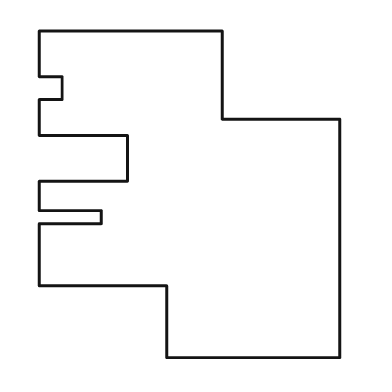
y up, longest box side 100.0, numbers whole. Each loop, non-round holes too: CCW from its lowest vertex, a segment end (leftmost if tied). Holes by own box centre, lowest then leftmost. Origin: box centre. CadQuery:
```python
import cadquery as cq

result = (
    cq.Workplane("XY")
    .moveTo(-7.0, -50.0)
    .lineTo(46.0, -50.0)
    .lineTo(46.0, 23.0)
    .lineTo(10.0, 23.0)
    .lineTo(10.0, 50.0)
    .lineTo(-46.0, 50.0)
    .lineTo(-46.0, 36.0)
    .lineTo(-39.0, 36.0)
    .lineTo(-39.0, 29.0)
    .lineTo(-46.0, 29.0)
    .lineTo(-46.0, 18.0)
    .lineTo(-19.0, 18.0)
    .lineTo(-19.0, 4.0)
    .lineTo(-46.0, 4.0)
    .lineTo(-46.0, -5.0)
    .lineTo(-27.0, -5.0)
    .lineTo(-27.0, -9.0)
    .lineTo(-46.0, -9.0)
    .lineTo(-46.0, -28.0)
    .lineTo(-7.0, -28.0)
    .close()
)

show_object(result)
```